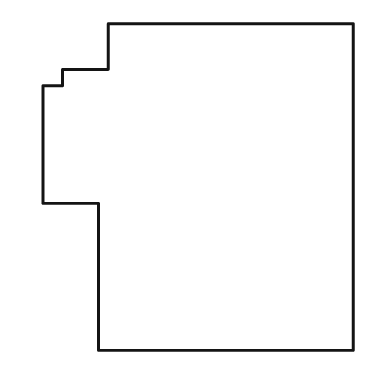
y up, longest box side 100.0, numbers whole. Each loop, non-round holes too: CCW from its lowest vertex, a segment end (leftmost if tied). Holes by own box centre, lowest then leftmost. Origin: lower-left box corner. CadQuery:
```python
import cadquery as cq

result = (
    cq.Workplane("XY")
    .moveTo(17.0, 0.0)
    .lineTo(95.0, 0.0)
    .lineTo(95.0, 100.0)
    .lineTo(20.0, 100.0)
    .lineTo(20.0, 86.0)
    .lineTo(6.0, 86.0)
    .lineTo(6.0, 81.0)
    .lineTo(0.0, 81.0)
    .lineTo(0.0, 45.0)
    .lineTo(17.0, 45.0)
    .close()
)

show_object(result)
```